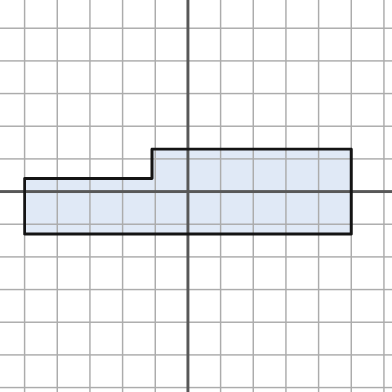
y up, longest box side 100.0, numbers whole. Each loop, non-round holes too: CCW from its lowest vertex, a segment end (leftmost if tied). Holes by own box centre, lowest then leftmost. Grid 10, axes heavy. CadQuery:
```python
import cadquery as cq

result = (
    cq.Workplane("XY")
    .moveTo(-50.0, -13.0)
    .lineTo(50.0, -13.0)
    .lineTo(50.0, 13.0)
    .lineTo(-11.0, 13.0)
    .lineTo(-11.0, 4.0)
    .lineTo(-50.0, 4.0)
    .close()
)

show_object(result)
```